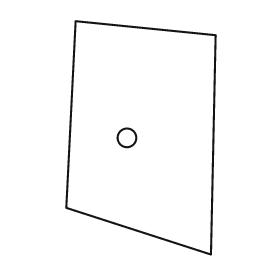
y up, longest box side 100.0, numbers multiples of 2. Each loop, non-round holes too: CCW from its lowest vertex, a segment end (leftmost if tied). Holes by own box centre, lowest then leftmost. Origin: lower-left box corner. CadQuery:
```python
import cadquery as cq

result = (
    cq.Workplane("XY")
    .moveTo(62.0, 0.0)
    .lineTo(64.0, 94.0)
    .lineTo(4.0, 100.0)
    .lineTo(0.0, 20.0)
    .close()
    .moveTo(26.0, 50.0)
    .circle(4.0)
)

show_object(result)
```